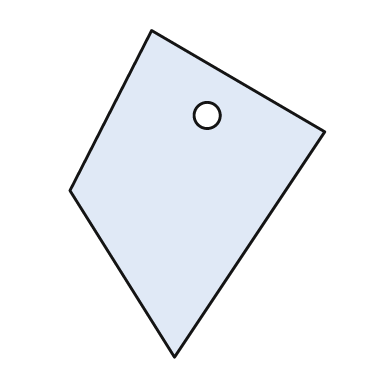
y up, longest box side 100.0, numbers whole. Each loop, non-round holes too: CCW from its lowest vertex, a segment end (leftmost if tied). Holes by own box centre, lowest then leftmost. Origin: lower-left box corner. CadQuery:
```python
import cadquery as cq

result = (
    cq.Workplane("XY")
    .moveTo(32.0, 0.0)
    .lineTo(78.0, 69.0)
    .lineTo(25.0, 100.0)
    .lineTo(0.0, 51.0)
    .close()
    .moveTo(42.0, 74.0)
    .circle(4.0)
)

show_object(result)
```